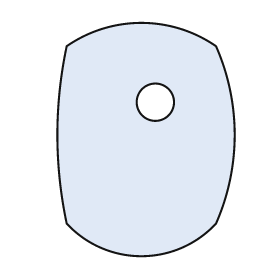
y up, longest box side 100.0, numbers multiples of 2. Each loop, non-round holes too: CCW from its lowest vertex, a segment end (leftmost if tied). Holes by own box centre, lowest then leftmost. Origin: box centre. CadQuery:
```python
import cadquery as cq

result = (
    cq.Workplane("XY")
    .moveTo(-34.0, -36.0)
    .threePointArc((-2.0, -50.0), (30.0, -36.0))
    .threePointArc((38.0, 2.0), (30.0, 40.0))
    .threePointArc((-2.0, 50.0), (-34.0, 40.0))
    .threePointArc((-38.0, 2.0), (-34.0, -36.0))
    .close()
    .moveTo(4.0, 16.0)
    .circle(8.0)
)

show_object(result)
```